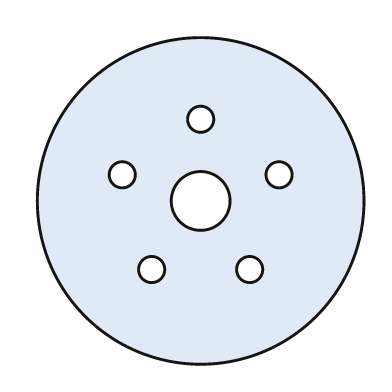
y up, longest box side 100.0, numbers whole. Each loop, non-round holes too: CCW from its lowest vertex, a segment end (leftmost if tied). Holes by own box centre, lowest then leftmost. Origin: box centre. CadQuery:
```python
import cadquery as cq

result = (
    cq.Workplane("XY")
    .moveTo(0.0, 0.0)
    .circle(50.0)
    .moveTo(-15.0, -21.0)
    .circle(4.0)
    .moveTo(15.0, -21.0)
    .circle(4.0)
    .moveTo(0.0, 0.0)
    .circle(9.0)
    .moveTo(-24.0, 8.0)
    .circle(4.0)
    .moveTo(24.0, 8.0)
    .circle(4.0)
    .moveTo(0.0, 25.0)
    .circle(4.0)
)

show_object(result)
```